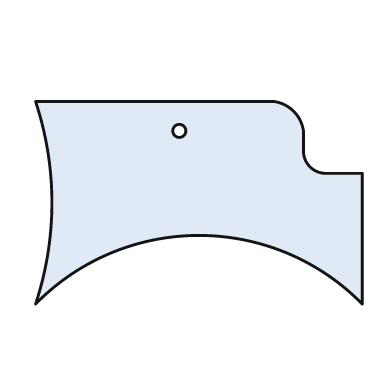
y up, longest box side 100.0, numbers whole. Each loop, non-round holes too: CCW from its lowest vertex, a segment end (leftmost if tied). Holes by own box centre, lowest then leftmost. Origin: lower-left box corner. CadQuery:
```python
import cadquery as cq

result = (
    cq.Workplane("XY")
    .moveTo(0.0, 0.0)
    .threePointArc((50.0, 21.0), (100.0, 0.0))
    .lineTo(100.0, 40.0)
    .lineTo(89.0, 40.0)
    .threePointArc((84.0, 42.0), (82.0, 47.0))
    .lineTo(82.0, 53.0)
    .threePointArc((79.0, 59.0), (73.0, 62.0))
    .lineTo(0.0, 62.0)
    .threePointArc((5.0, 31.0), (0.0, 0.0))
    .close()
    .moveTo(44.0, 53.0)
    .circle(2.0)
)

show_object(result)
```